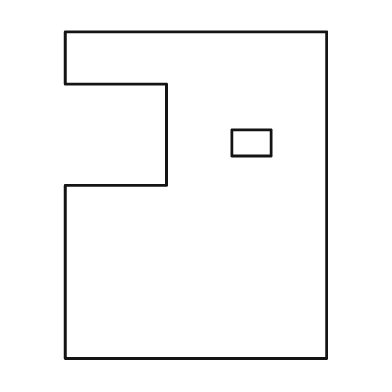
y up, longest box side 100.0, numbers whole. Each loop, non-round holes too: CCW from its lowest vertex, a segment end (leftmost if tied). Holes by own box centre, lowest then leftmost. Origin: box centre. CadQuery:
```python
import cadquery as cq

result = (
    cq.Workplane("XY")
    .moveTo(-40.0, -50.0)
    .lineTo(40.0, -50.0)
    .lineTo(40.0, 50.0)
    .lineTo(-40.0, 50.0)
    .lineTo(-40.0, 34.0)
    .lineTo(-9.0, 34.0)
    .lineTo(-9.0, 3.0)
    .lineTo(-40.0, 3.0)
    .close()
    .moveTo(11.0, 12.0)
    .lineTo(23.0, 12.0)
    .lineTo(23.0, 20.0)
    .lineTo(11.0, 20.0)
    .close()
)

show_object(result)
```